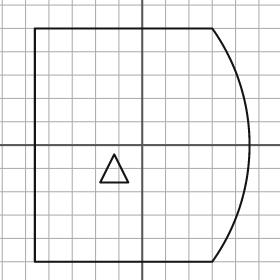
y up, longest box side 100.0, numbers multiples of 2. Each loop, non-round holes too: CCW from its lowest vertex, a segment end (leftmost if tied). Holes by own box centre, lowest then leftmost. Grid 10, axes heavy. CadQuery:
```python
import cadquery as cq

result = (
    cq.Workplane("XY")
    .moveTo(-46.0, -50.0)
    .lineTo(30.0, -50.0)
    .threePointArc((46.0, 0.0), (30.0, 50.0))
    .lineTo(-46.0, 50.0)
    .close()
    .moveTo(-18.0, -16.0)
    .lineTo(-6.0, -16.0)
    .lineTo(-12.0, -4.0)
    .close()
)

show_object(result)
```